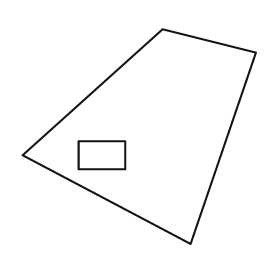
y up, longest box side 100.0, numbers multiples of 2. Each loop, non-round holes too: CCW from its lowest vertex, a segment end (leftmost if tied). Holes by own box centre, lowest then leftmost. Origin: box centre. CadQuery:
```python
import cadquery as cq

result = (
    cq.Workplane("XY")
    .moveTo(22.0, -46.0)
    .lineTo(50.0, 36.0)
    .lineTo(10.0, 46.0)
    .lineTo(-50.0, -8.0)
    .close()
    .moveTo(-26.0, -14.0)
    .lineTo(-6.0, -14.0)
    .lineTo(-6.0, -2.0)
    .lineTo(-26.0, -2.0)
    .close()
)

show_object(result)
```